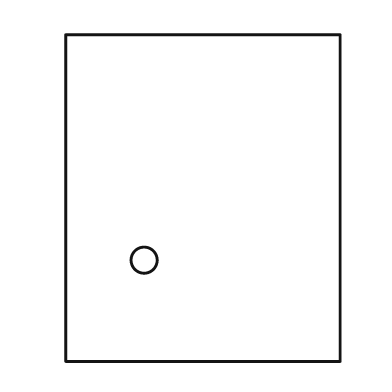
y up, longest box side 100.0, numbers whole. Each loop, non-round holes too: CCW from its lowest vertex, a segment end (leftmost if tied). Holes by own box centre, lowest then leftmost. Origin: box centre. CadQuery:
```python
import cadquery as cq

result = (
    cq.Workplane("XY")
    .moveTo(-42.0, -50.0)
    .lineTo(42.0, -50.0)
    .lineTo(42.0, 50.0)
    .lineTo(-42.0, 50.0)
    .close()
    .moveTo(-18.0, -19.0)
    .circle(4.0)
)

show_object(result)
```